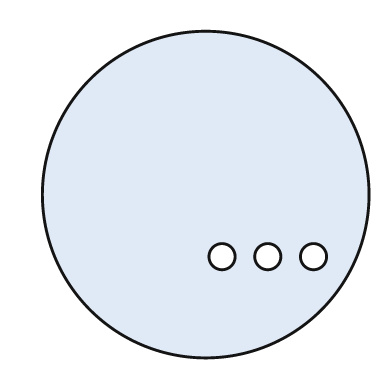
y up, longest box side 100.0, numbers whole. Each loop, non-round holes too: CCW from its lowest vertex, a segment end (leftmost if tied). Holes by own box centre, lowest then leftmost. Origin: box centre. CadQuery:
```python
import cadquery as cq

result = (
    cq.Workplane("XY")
    .moveTo(0.0, 0.0)
    .circle(50.0)
    .moveTo(5.0, -19.0)
    .circle(4.0)
    .moveTo(19.0, -19.0)
    .circle(4.0)
    .moveTo(33.0, -19.0)
    .circle(4.0)
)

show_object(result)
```